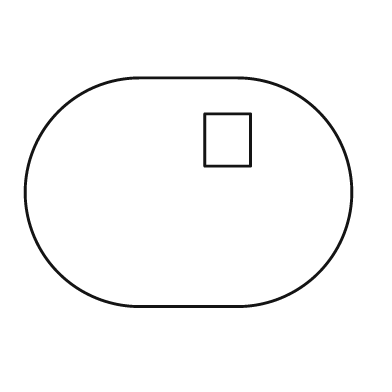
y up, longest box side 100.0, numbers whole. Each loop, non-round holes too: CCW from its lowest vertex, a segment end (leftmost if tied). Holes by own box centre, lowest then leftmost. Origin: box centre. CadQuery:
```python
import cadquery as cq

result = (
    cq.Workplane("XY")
    .moveTo(-15.0, -35.0)
    .lineTo(15.0, -35.0)
    .threePointArc((50.0, 0.0), (15.0, 35.0))
    .lineTo(-15.0, 35.0)
    .threePointArc((-50.0, 0.0), (-15.0, -35.0))
    .close()
    .moveTo(5.0, 8.0)
    .lineTo(19.0, 8.0)
    .lineTo(19.0, 24.0)
    .lineTo(5.0, 24.0)
    .close()
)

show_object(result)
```